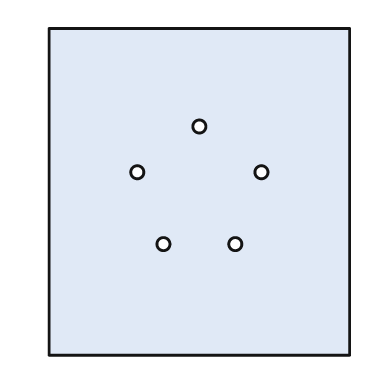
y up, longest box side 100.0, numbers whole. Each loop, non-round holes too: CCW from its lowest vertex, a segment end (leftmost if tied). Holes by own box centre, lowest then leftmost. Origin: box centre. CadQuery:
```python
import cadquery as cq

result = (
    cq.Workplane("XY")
    .moveTo(-46.0, -50.0)
    .lineTo(46.0, -50.0)
    .lineTo(46.0, 50.0)
    .lineTo(-46.0, 50.0)
    .close()
    .moveTo(-11.0, -16.0)
    .circle(2.0)
    .moveTo(11.0, -16.0)
    .circle(2.0)
    .moveTo(-19.0, 6.0)
    .circle(2.0)
    .moveTo(19.0, 6.0)
    .circle(2.0)
    .moveTo(0.0, 20.0)
    .circle(2.0)
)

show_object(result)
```